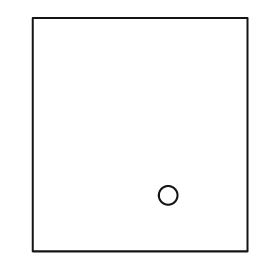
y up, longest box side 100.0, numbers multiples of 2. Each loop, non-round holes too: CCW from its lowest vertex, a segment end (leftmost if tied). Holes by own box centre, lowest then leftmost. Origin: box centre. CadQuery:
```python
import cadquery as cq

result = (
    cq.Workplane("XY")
    .moveTo(-46.0, -50.0)
    .lineTo(46.0, -50.0)
    .lineTo(46.0, 50.0)
    .lineTo(-46.0, 50.0)
    .close()
    .moveTo(12.0, -26.0)
    .circle(4.0)
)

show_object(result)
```